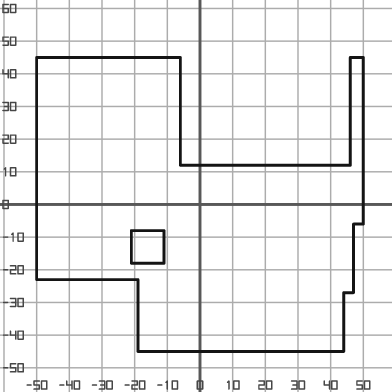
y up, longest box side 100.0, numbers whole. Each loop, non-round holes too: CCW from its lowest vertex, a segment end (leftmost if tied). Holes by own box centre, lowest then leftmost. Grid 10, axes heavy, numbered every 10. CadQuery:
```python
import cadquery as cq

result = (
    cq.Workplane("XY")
    .moveTo(-19.0, -45.0)
    .lineTo(44.0, -45.0)
    .lineTo(44.0, -27.0)
    .lineTo(47.0, -27.0)
    .lineTo(47.0, -6.0)
    .lineTo(50.0, -6.0)
    .lineTo(50.0, 45.0)
    .lineTo(46.0, 45.0)
    .lineTo(46.0, 12.0)
    .lineTo(-6.0, 12.0)
    .lineTo(-6.0, 45.0)
    .lineTo(-50.0, 45.0)
    .lineTo(-50.0, -23.0)
    .lineTo(-19.0, -23.0)
    .close()
    .moveTo(-21.0, -18.0)
    .lineTo(-11.0, -18.0)
    .lineTo(-11.0, -8.0)
    .lineTo(-21.0, -8.0)
    .close()
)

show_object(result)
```